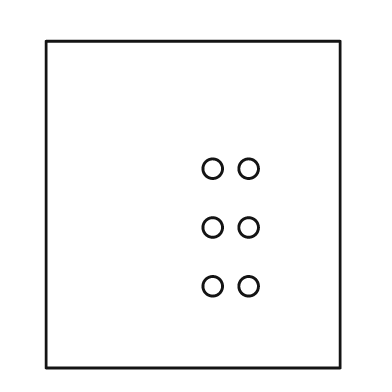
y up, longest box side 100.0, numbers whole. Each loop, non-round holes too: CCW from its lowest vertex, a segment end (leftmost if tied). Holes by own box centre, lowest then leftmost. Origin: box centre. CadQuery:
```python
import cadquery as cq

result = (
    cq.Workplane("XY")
    .moveTo(-45.0, -50.0)
    .lineTo(45.0, -50.0)
    .lineTo(45.0, 50.0)
    .lineTo(-45.0, 50.0)
    .close()
    .moveTo(6.0, -25.0)
    .circle(3.0)
    .moveTo(17.0, -25.0)
    .circle(3.0)
    .moveTo(6.0, -7.0)
    .circle(3.0)
    .moveTo(17.0, -7.0)
    .circle(3.0)
    .moveTo(6.0, 11.0)
    .circle(3.0)
    .moveTo(17.0, 11.0)
    .circle(3.0)
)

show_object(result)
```